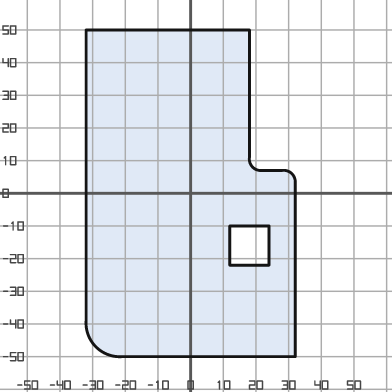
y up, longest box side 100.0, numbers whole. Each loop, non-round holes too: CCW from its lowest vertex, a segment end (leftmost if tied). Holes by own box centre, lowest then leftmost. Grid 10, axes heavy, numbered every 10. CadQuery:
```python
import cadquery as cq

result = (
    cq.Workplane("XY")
    .moveTo(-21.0, -50.0)
    .lineTo(32.0, -50.0)
    .lineTo(32.0, 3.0)
    .threePointArc((31.0, 6.0), (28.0, 7.0))
    .lineTo(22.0, 7.0)
    .threePointArc((19.0, 8.0), (18.0, 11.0))
    .lineTo(18.0, 50.0)
    .lineTo(-32.0, 50.0)
    .lineTo(-32.0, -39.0)
    .threePointArc((-29.0, -47.0), (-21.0, -50.0))
    .close()
    .moveTo(12.0, -22.0)
    .lineTo(24.0, -22.0)
    .lineTo(24.0, -10.0)
    .lineTo(12.0, -10.0)
    .close()
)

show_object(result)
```